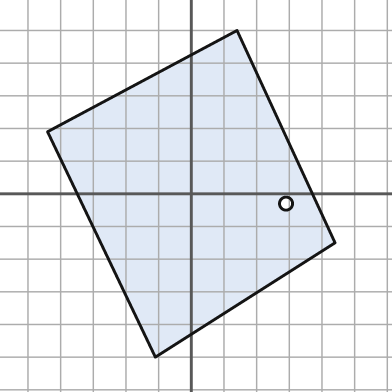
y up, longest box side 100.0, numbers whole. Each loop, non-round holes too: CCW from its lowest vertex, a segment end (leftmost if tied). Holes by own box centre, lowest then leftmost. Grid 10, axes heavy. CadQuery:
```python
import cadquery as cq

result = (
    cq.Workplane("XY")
    .moveTo(-11.0, -50.0)
    .lineTo(44.0, -15.0)
    .lineTo(14.0, 50.0)
    .lineTo(-44.0, 19.0)
    .close()
    .moveTo(29.0, -3.0)
    .circle(2.0)
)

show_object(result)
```